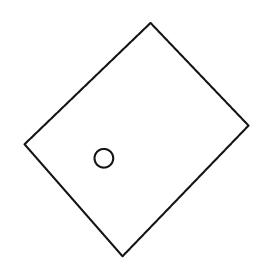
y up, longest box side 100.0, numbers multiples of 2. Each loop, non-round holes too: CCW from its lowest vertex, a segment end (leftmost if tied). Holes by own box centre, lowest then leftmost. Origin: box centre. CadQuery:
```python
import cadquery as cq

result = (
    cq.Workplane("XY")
    .moveTo(-6.0, -50.0)
    .lineTo(48.0, 6.0)
    .lineTo(6.0, 50.0)
    .lineTo(-48.0, -2.0)
    .close()
    .moveTo(-14.0, -8.0)
    .circle(4.0)
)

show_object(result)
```